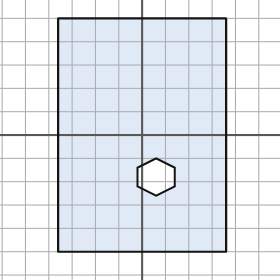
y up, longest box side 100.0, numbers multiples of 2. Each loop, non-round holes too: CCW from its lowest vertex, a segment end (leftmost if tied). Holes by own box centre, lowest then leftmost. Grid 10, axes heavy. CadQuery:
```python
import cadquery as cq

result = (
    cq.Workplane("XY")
    .moveTo(-36.0, -50.0)
    .lineTo(36.0, -50.0)
    .lineTo(36.0, 50.0)
    .lineTo(-36.0, 50.0)
    .close()
    .moveTo(6.0, -26.0)
    .lineTo(14.0, -22.0)
    .lineTo(14.0, -14.0)
    .lineTo(6.0, -10.0)
    .lineTo(-2.0, -14.0)
    .lineTo(-2.0, -22.0)
    .close()
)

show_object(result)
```